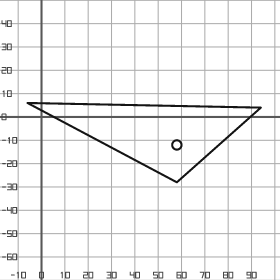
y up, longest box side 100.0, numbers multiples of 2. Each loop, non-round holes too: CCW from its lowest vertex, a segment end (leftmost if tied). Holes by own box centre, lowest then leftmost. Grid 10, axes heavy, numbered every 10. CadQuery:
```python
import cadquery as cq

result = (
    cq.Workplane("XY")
    .moveTo(58.0, -28.0)
    .lineTo(94.0, 4.0)
    .lineTo(-6.0, 6.0)
    .close()
    .moveTo(58.0, -12.0)
    .circle(2.0)
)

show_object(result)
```